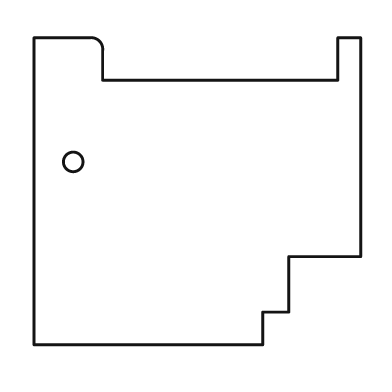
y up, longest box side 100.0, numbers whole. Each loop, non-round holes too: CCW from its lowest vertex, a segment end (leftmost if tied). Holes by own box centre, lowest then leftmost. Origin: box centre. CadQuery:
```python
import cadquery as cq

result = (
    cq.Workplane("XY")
    .moveTo(-50.0, -47.0)
    .lineTo(20.0, -47.0)
    .lineTo(20.0, -37.0)
    .lineTo(28.0, -37.0)
    .lineTo(28.0, -20.0)
    .lineTo(50.0, -20.0)
    .lineTo(50.0, 47.0)
    .lineTo(43.0, 47.0)
    .lineTo(43.0, 34.0)
    .lineTo(-29.0, 34.0)
    .lineTo(-29.0, 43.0)
    .threePointArc((-30.0, 46.0), (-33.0, 47.0))
    .lineTo(-50.0, 47.0)
    .close()
    .moveTo(-38.0, 9.0)
    .circle(3.0)
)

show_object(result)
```